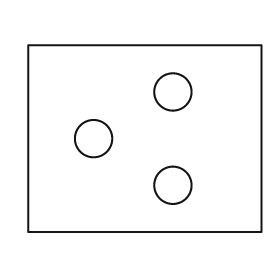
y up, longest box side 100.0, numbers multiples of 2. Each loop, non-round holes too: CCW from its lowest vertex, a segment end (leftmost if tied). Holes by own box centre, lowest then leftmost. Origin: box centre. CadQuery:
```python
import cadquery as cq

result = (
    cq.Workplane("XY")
    .moveTo(-50.0, -40.0)
    .lineTo(50.0, -40.0)
    .lineTo(50.0, 40.0)
    .lineTo(-50.0, 40.0)
    .close()
    .moveTo(12.0, -20.0)
    .circle(8.0)
    .moveTo(-22.0, 0.0)
    .circle(8.0)
    .moveTo(12.0, 20.0)
    .circle(8.0)
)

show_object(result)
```